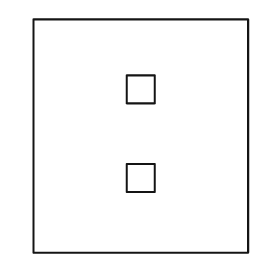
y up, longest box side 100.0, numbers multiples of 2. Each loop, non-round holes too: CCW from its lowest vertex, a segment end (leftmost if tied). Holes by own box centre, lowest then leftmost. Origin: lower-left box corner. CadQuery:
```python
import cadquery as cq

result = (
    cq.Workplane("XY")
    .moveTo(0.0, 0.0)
    .lineTo(92.0, 0.0)
    .lineTo(92.0, 100.0)
    .lineTo(0.0, 100.0)
    .close()
    .moveTo(40.0, 26.0)
    .lineTo(52.0, 26.0)
    .lineTo(52.0, 38.0)
    .lineTo(40.0, 38.0)
    .close()
    .moveTo(40.0, 64.0)
    .lineTo(52.0, 64.0)
    .lineTo(52.0, 76.0)
    .lineTo(40.0, 76.0)
    .close()
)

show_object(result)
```